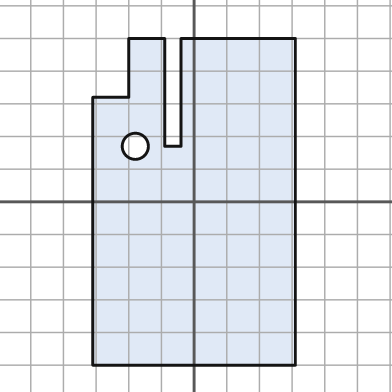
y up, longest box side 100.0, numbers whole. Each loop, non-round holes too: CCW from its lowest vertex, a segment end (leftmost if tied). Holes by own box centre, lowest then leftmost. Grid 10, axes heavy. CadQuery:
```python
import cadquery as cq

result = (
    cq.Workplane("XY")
    .moveTo(-31.0, -50.0)
    .lineTo(31.0, -50.0)
    .lineTo(31.0, 50.0)
    .lineTo(-4.0, 50.0)
    .lineTo(-4.0, 17.0)
    .lineTo(-9.0, 17.0)
    .lineTo(-9.0, 50.0)
    .lineTo(-20.0, 50.0)
    .lineTo(-20.0, 32.0)
    .lineTo(-31.0, 32.0)
    .close()
    .moveTo(-18.0, 17.0)
    .circle(4.0)
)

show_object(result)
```